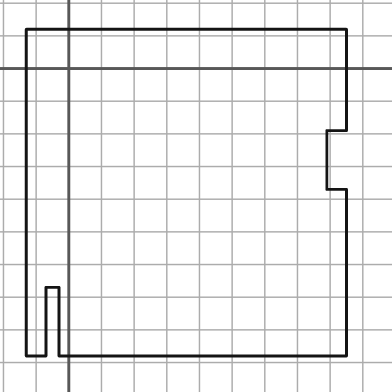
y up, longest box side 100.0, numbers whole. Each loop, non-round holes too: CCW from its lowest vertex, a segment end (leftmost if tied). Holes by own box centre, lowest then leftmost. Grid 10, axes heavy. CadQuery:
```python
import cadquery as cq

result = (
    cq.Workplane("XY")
    .moveTo(-13.0, -88.0)
    .lineTo(-7.0, -88.0)
    .lineTo(-7.0, -67.0)
    .lineTo(-3.0, -67.0)
    .lineTo(-3.0, -88.0)
    .lineTo(85.0, -88.0)
    .lineTo(85.0, -37.0)
    .lineTo(79.0, -37.0)
    .lineTo(79.0, -19.0)
    .lineTo(85.0, -19.0)
    .lineTo(85.0, 12.0)
    .lineTo(-13.0, 12.0)
    .close()
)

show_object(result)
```